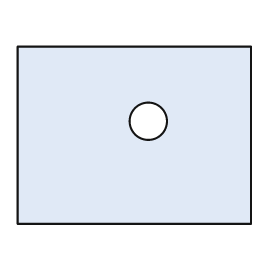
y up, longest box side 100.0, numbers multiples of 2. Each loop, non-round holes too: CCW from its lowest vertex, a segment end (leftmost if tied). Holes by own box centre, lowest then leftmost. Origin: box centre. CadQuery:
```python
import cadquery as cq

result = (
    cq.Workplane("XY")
    .moveTo(-50.0, -38.0)
    .lineTo(50.0, -38.0)
    .lineTo(50.0, 38.0)
    .lineTo(-50.0, 38.0)
    .close()
    .moveTo(6.0, 6.0)
    .circle(8.0)
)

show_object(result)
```